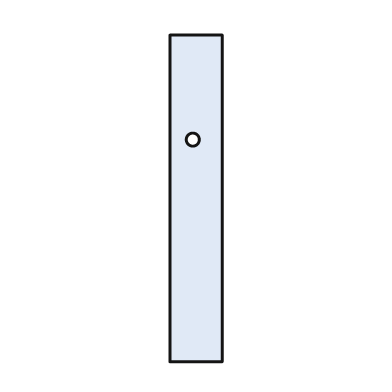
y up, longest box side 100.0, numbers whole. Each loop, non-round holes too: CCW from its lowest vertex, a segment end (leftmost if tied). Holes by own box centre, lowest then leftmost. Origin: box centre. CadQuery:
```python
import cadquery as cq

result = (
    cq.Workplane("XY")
    .moveTo(-8.0, -50.0)
    .lineTo(8.0, -50.0)
    .lineTo(8.0, 50.0)
    .lineTo(-8.0, 50.0)
    .close()
    .moveTo(-1.0, 18.0)
    .circle(2.0)
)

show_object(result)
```